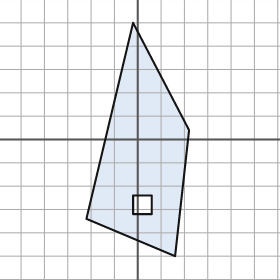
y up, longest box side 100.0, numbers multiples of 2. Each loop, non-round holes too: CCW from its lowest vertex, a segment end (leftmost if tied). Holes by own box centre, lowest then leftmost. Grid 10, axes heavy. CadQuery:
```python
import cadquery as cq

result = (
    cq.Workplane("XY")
    .moveTo(16.0, -50.0)
    .lineTo(22.0, 4.0)
    .lineTo(-2.0, 50.0)
    .lineTo(-22.0, -34.0)
    .close()
    .moveTo(-2.0, -32.0)
    .lineTo(6.0, -32.0)
    .lineTo(6.0, -24.0)
    .lineTo(-2.0, -24.0)
    .close()
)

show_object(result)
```